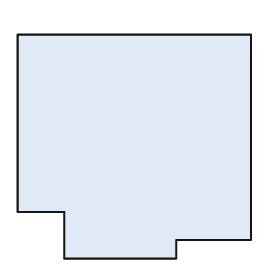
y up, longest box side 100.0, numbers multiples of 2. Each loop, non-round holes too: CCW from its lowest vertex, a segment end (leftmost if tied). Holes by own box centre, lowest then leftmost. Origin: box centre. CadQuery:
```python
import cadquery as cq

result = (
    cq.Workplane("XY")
    .moveTo(-30.0, -48.0)
    .lineTo(18.0, -48.0)
    .lineTo(18.0, -40.0)
    .lineTo(50.0, -40.0)
    .lineTo(50.0, 48.0)
    .lineTo(-50.0, 48.0)
    .lineTo(-50.0, -28.0)
    .lineTo(-30.0, -28.0)
    .close()
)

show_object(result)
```